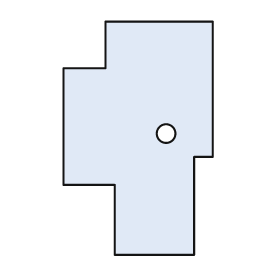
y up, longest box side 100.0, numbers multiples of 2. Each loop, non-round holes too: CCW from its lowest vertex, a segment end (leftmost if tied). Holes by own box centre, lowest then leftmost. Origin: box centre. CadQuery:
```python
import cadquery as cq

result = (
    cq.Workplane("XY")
    .moveTo(-10.0, -50.0)
    .lineTo(24.0, -50.0)
    .lineTo(24.0, -8.0)
    .lineTo(32.0, -8.0)
    .lineTo(32.0, 50.0)
    .lineTo(-14.0, 50.0)
    .lineTo(-14.0, 30.0)
    .lineTo(-32.0, 30.0)
    .lineTo(-32.0, -20.0)
    .lineTo(-10.0, -20.0)
    .close()
    .moveTo(12.0, 2.0)
    .circle(4.0)
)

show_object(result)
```